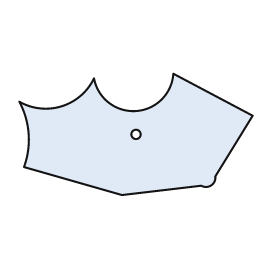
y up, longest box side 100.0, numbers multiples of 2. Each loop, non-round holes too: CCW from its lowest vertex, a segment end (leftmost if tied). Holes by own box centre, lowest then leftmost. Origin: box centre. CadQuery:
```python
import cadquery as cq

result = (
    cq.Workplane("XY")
    .moveTo(-6.0, -26.0)
    .lineTo(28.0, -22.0)
    .threePointArc((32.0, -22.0), (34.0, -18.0))
    .lineTo(50.0, 8.0)
    .lineTo(16.0, 26.0)
    .threePointArc((0.0, 10.0), (-18.0, 24.0))
    .threePointArc((-32.0, 12.0), (-50.0, 14.0))
    .threePointArc((-46.0, 0.0), (-48.0, -14.0))
    .close()
    .moveTo(0.0, 0.0)
    .circle(2.0)
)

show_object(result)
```